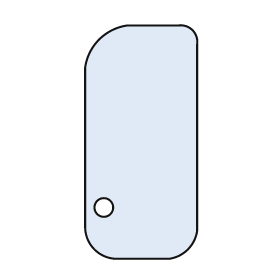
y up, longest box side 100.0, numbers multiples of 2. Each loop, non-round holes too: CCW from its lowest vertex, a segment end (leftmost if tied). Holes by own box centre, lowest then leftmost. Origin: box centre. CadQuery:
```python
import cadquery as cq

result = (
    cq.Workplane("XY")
    .moveTo(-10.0, -50.0)
    .lineTo(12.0, -50.0)
    .threePointArc((20.0, -46.0), (24.0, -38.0))
    .lineTo(24.0, 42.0)
    .threePointArc((22.0, 48.0), (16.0, 50.0))
    .lineTo(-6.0, 50.0)
    .threePointArc((-18.0, 44.0), (-24.0, 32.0))
    .lineTo(-24.0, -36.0)
    .threePointArc((-20.0, -46.0), (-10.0, -50.0))
    .close()
    .moveTo(-16.0, -28.0)
    .circle(4.0)
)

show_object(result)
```